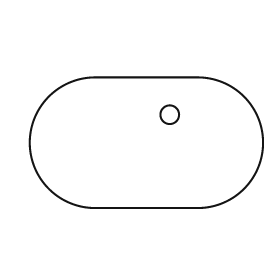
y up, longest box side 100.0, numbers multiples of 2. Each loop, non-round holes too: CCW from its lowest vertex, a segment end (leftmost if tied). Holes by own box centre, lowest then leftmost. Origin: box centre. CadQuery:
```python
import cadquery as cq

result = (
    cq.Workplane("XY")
    .moveTo(-22.0, -28.0)
    .lineTo(22.0, -28.0)
    .threePointArc((50.0, 0.0), (22.0, 28.0))
    .lineTo(-22.0, 28.0)
    .threePointArc((-50.0, 0.0), (-22.0, -28.0))
    .close()
    .moveTo(10.0, 12.0)
    .circle(4.0)
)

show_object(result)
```